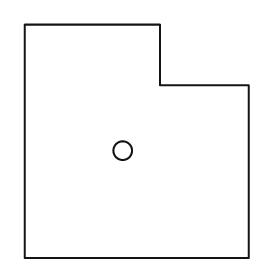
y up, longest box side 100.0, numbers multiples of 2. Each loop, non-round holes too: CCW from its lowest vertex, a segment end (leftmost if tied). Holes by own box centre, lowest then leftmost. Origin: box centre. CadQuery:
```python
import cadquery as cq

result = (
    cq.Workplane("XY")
    .moveTo(-48.0, -50.0)
    .lineTo(48.0, -50.0)
    .lineTo(48.0, 24.0)
    .lineTo(10.0, 24.0)
    .lineTo(10.0, 50.0)
    .lineTo(-48.0, 50.0)
    .close()
    .moveTo(-6.0, -4.0)
    .circle(4.0)
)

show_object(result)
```